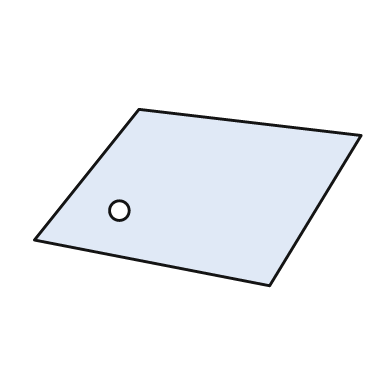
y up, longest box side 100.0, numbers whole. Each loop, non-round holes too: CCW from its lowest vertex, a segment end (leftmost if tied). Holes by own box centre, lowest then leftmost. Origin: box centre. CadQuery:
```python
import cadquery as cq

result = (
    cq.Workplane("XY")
    .moveTo(22.0, -27.0)
    .lineTo(50.0, 19.0)
    .lineTo(-18.0, 27.0)
    .lineTo(-50.0, -13.0)
    .close()
    .moveTo(-24.0, -4.0)
    .circle(3.0)
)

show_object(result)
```